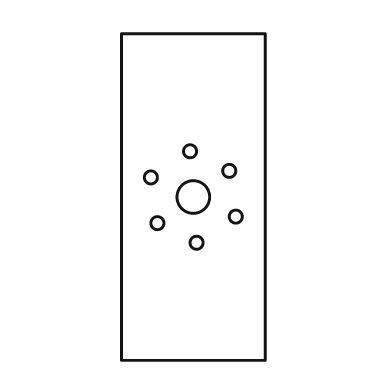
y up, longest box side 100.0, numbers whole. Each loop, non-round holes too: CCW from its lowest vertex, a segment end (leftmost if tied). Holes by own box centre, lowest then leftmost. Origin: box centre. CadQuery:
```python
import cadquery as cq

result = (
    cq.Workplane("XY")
    .moveTo(-22.0, -50.0)
    .lineTo(22.0, -50.0)
    .lineTo(22.0, 50.0)
    .lineTo(-22.0, 50.0)
    .close()
    .moveTo(1.0, -14.0)
    .circle(2.0)
    .moveTo(-11.0, -8.0)
    .circle(2.0)
    .moveTo(13.0, -6.0)
    .circle(2.0)
    .moveTo(0.0, 0.0)
    .circle(5.0)
    .moveTo(-13.0, 6.0)
    .circle(2.0)
    .moveTo(11.0, 8.0)
    .circle(2.0)
    .moveTo(-1.0, 14.0)
    .circle(2.0)
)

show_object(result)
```